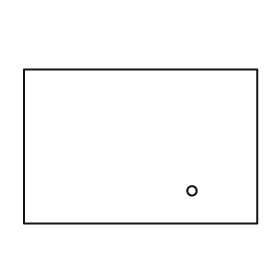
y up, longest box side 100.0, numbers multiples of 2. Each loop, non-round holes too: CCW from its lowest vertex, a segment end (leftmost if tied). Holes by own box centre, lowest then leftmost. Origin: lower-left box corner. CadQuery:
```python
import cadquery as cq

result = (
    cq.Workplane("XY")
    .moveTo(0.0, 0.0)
    .lineTo(100.0, 0.0)
    .lineTo(100.0, 66.0)
    .lineTo(0.0, 66.0)
    .close()
    .moveTo(72.0, 14.0)
    .circle(2.0)
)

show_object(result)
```